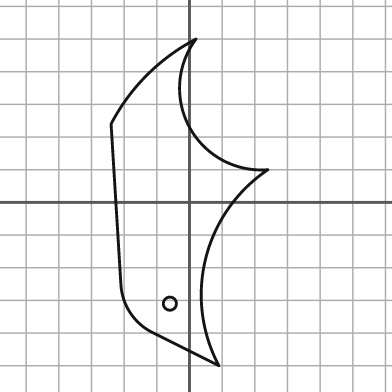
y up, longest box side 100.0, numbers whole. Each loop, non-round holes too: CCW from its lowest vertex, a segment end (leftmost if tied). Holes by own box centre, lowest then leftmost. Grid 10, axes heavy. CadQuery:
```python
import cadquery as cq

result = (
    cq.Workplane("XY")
    .moveTo(9.0, -50.0)
    .threePointArc((5.0, -17.0), (24.0, 10.0))
    .threePointArc((0.0, 23.0), (2.0, 50.0))
    .threePointArc((-13.0, 39.0), (-24.0, 24.0))
    .lineTo(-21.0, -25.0)
    .threePointArc((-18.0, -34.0), (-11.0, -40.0))
    .close()
    .moveTo(-6.0, -31.0)
    .circle(2.0)
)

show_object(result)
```